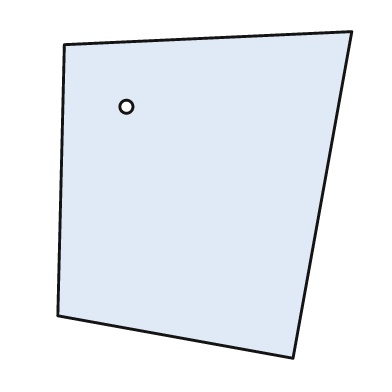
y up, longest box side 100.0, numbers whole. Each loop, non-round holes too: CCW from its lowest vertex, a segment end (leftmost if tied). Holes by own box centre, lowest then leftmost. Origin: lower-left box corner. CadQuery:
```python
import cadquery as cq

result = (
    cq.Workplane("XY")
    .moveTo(72.0, 0.0)
    .lineTo(90.0, 100.0)
    .lineTo(2.0, 96.0)
    .lineTo(0.0, 13.0)
    .close()
    .moveTo(21.0, 77.0)
    .circle(2.0)
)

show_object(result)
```